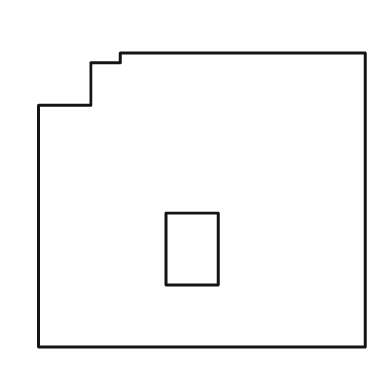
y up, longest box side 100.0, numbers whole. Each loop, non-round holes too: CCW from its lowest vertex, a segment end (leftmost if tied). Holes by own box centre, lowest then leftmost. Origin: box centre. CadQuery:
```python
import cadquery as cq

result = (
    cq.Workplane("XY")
    .moveTo(-50.0, -45.0)
    .lineTo(50.0, -45.0)
    .lineTo(50.0, 45.0)
    .lineTo(-25.0, 45.0)
    .lineTo(-25.0, 42.0)
    .lineTo(-34.0, 42.0)
    .lineTo(-34.0, 29.0)
    .lineTo(-50.0, 29.0)
    .close()
    .moveTo(-11.0, -26.0)
    .lineTo(5.0, -26.0)
    .lineTo(5.0, -4.0)
    .lineTo(-11.0, -4.0)
    .close()
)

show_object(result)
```